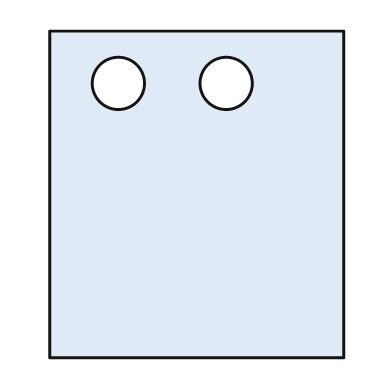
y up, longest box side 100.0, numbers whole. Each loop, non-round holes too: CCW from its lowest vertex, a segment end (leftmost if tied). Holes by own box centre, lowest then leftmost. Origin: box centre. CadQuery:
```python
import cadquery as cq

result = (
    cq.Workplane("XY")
    .moveTo(-45.0, -50.0)
    .lineTo(45.0, -50.0)
    .lineTo(45.0, 50.0)
    .lineTo(-45.0, 50.0)
    .close()
    .moveTo(-24.0, 34.0)
    .circle(8.0)
    .moveTo(9.0, 34.0)
    .circle(8.0)
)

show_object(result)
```